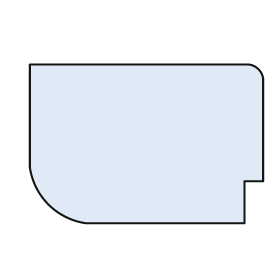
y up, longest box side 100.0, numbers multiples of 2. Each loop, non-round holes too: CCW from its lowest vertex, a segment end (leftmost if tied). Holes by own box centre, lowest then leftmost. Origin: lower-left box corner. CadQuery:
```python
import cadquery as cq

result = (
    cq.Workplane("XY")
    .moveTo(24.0, 0.0)
    .lineTo(92.0, 0.0)
    .lineTo(92.0, 18.0)
    .lineTo(100.0, 18.0)
    .lineTo(100.0, 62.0)
    .threePointArc((98.0, 66.0), (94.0, 68.0))
    .lineTo(0.0, 68.0)
    .lineTo(0.0, 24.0)
    .threePointArc((8.0, 8.0), (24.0, 0.0))
    .close()
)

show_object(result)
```